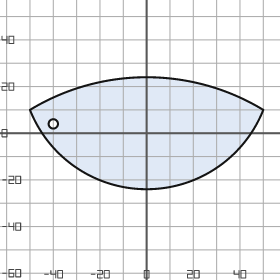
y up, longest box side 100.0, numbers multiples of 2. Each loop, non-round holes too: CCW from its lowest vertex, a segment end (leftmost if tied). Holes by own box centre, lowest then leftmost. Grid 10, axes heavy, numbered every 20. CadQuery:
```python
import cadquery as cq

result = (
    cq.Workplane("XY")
    .moveTo(-50.0, 10.0)
    .threePointArc((0.0, -24.0), (50.0, 10.0))
    .threePointArc((0.0, 24.0), (-50.0, 10.0))
    .close()
    .moveTo(-40.0, 4.0)
    .circle(2.0)
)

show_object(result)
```